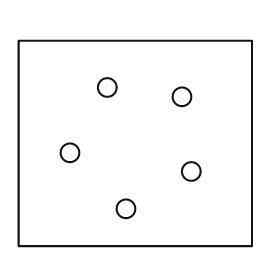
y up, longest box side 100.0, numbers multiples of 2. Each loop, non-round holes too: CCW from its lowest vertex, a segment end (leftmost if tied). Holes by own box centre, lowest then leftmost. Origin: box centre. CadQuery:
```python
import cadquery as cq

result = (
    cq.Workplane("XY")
    .moveTo(-50.0, -44.0)
    .lineTo(50.0, -44.0)
    .lineTo(50.0, 44.0)
    .lineTo(-50.0, 44.0)
    .close()
    .moveTo(-4.0, -28.0)
    .circle(4.0)
    .moveTo(24.0, -12.0)
    .circle(4.0)
    .moveTo(-28.0, -4.0)
    .circle(4.0)
    .moveTo(20.0, 20.0)
    .circle(4.0)
    .moveTo(-12.0, 24.0)
    .circle(4.0)
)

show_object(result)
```